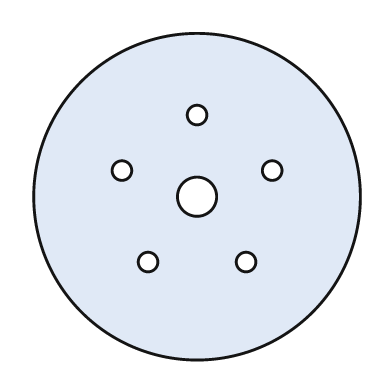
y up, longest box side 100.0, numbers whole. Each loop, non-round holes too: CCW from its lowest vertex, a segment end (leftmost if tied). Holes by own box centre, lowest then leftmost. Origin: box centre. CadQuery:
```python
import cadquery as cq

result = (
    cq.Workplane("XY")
    .moveTo(0.0, 0.0)
    .circle(50.0)
    .moveTo(-15.0, -20.0)
    .circle(3.0)
    .moveTo(15.0, -20.0)
    .circle(3.0)
    .moveTo(0.0, 0.0)
    .circle(6.0)
    .moveTo(-23.0, 8.0)
    .circle(3.0)
    .moveTo(23.0, 8.0)
    .circle(3.0)
    .moveTo(0.0, 25.0)
    .circle(3.0)
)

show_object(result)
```